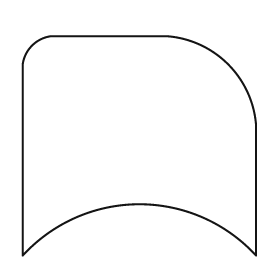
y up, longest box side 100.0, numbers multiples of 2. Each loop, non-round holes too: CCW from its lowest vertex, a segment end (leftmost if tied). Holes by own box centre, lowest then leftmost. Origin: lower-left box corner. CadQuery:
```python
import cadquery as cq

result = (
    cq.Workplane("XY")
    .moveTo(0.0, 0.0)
    .threePointArc((50.0, 22.0), (100.0, 0.0))
    .lineTo(100.0, 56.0)
    .threePointArc((88.0, 82.0), (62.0, 94.0))
    .lineTo(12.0, 94.0)
    .threePointArc((4.0, 90.0), (0.0, 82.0))
    .close()
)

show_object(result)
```